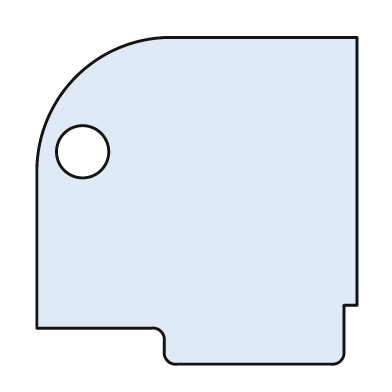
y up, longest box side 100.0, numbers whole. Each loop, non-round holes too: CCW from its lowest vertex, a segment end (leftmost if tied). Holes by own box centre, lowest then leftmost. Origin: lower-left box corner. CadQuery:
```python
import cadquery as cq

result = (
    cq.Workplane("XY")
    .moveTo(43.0, 0.0)
    .lineTo(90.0, 0.0)
    .threePointArc((93.0, 1.0), (94.0, 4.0))
    .lineTo(94.0, 18.0)
    .lineTo(98.0, 18.0)
    .lineTo(98.0, 100.0)
    .lineTo(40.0, 100.0)
    .threePointArc((12.0, 88.0), (0.0, 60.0))
    .lineTo(0.0, 11.0)
    .lineTo(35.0, 11.0)
    .threePointArc((38.0, 10.0), (39.0, 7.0))
    .lineTo(39.0, 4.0)
    .threePointArc((40.0, 1.0), (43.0, 0.0))
    .close()
    .moveTo(14.0, 65.0)
    .circle(8.0)
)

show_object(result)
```